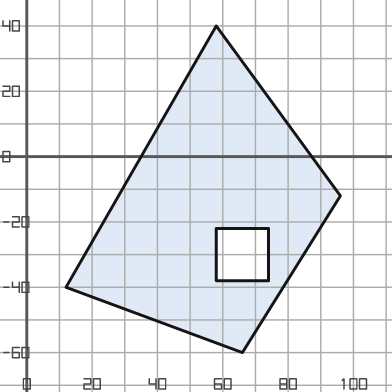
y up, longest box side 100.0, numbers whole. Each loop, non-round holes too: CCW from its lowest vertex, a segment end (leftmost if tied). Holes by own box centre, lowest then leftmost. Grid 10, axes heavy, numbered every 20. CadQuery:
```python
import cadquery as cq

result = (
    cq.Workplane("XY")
    .moveTo(66.0, -60.0)
    .lineTo(96.0, -12.0)
    .lineTo(58.0, 40.0)
    .lineTo(12.0, -40.0)
    .close()
    .moveTo(58.0, -38.0)
    .lineTo(74.0, -38.0)
    .lineTo(74.0, -22.0)
    .lineTo(58.0, -22.0)
    .close()
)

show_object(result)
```